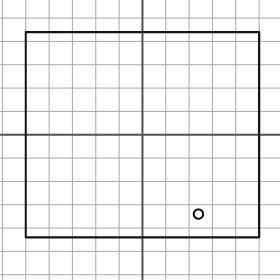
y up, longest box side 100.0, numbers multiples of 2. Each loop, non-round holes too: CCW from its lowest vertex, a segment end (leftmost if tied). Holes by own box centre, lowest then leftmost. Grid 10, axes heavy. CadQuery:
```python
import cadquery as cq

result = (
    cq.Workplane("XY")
    .moveTo(-50.0, -44.0)
    .lineTo(50.0, -44.0)
    .lineTo(50.0, 44.0)
    .lineTo(-50.0, 44.0)
    .close()
    .moveTo(24.0, -34.0)
    .circle(2.0)
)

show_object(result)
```